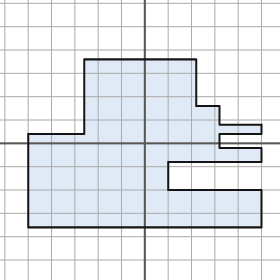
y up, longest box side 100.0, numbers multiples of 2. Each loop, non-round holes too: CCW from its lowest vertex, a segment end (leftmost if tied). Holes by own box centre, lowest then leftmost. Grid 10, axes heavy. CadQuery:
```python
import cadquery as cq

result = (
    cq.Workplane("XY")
    .moveTo(-50.0, -36.0)
    .lineTo(50.0, -36.0)
    .lineTo(50.0, -20.0)
    .lineTo(10.0, -20.0)
    .lineTo(10.0, -8.0)
    .lineTo(50.0, -8.0)
    .lineTo(50.0, -2.0)
    .lineTo(32.0, -2.0)
    .lineTo(32.0, 4.0)
    .lineTo(50.0, 4.0)
    .lineTo(50.0, 8.0)
    .lineTo(32.0, 8.0)
    .lineTo(32.0, 16.0)
    .lineTo(22.0, 16.0)
    .lineTo(22.0, 36.0)
    .lineTo(-26.0, 36.0)
    .lineTo(-26.0, 4.0)
    .lineTo(-50.0, 4.0)
    .close()
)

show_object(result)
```